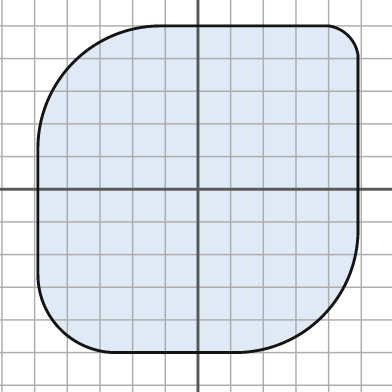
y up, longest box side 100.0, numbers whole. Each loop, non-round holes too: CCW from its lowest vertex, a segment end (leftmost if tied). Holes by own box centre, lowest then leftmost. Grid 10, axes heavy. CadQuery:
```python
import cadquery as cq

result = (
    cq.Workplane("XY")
    .moveTo(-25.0, -50.0)
    .lineTo(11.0, -50.0)
    .threePointArc((38.0, -39.0), (49.0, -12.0))
    .lineTo(49.0, 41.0)
    .threePointArc((46.0, 47.0), (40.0, 50.0))
    .lineTo(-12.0, 50.0)
    .threePointArc((-38.0, 39.0), (-49.0, 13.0))
    .lineTo(-49.0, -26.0)
    .threePointArc((-42.0, -43.0), (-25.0, -50.0))
    .close()
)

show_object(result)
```